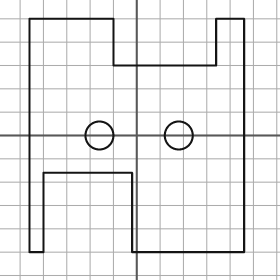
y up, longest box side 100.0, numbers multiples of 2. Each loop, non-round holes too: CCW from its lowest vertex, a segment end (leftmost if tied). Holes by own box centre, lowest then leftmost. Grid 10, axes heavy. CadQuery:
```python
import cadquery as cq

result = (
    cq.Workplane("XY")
    .moveTo(-46.0, -50.0)
    .lineTo(-40.0, -50.0)
    .lineTo(-40.0, -16.0)
    .lineTo(-2.0, -16.0)
    .lineTo(-2.0, -50.0)
    .lineTo(46.0, -50.0)
    .lineTo(46.0, 50.0)
    .lineTo(34.0, 50.0)
    .lineTo(34.0, 30.0)
    .lineTo(-10.0, 30.0)
    .lineTo(-10.0, 50.0)
    .lineTo(-46.0, 50.0)
    .close()
    .moveTo(-16.0, 0.0)
    .circle(6.0)
    .moveTo(18.0, 0.0)
    .circle(6.0)
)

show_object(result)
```